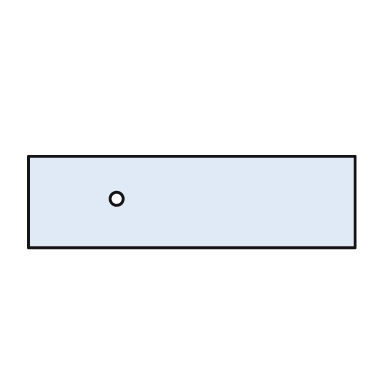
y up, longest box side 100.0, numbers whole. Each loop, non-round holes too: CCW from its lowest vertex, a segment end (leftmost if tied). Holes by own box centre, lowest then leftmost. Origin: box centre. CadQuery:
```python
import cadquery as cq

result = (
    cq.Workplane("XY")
    .moveTo(-50.0, -14.0)
    .lineTo(50.0, -14.0)
    .lineTo(50.0, 14.0)
    .lineTo(-50.0, 14.0)
    .close()
    .moveTo(-23.0, 1.0)
    .circle(2.0)
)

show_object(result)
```